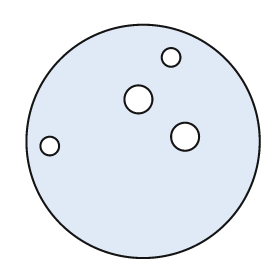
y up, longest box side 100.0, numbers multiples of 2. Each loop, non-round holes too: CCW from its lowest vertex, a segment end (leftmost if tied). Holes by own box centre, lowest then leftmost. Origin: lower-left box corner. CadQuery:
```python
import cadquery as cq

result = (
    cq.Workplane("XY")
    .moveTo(50.0, 50.0)
    .circle(50.0)
    .moveTo(10.0, 48.0)
    .circle(4.0)
    .moveTo(68.0, 52.0)
    .circle(6.0)
    .moveTo(48.0, 68.0)
    .circle(6.0)
    .moveTo(62.0, 86.0)
    .circle(4.0)
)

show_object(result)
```